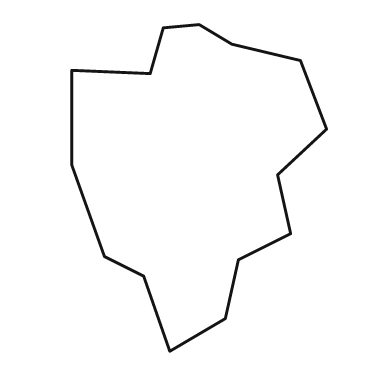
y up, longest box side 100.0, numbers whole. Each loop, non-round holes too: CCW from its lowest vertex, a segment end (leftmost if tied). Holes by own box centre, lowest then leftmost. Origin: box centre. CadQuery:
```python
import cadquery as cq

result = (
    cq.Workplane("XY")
    .moveTo(-9.0, -50.0)
    .lineTo(8.0, -40.0)
    .lineTo(12.0, -22.0)
    .lineTo(28.0, -14.0)
    .lineTo(24.0, 4.0)
    .lineTo(39.0, 18.0)
    .lineTo(31.0, 39.0)
    .lineTo(10.0, 44.0)
    .lineTo(0.0, 50.0)
    .lineTo(-11.0, 49.0)
    .lineTo(-15.0, 35.0)
    .lineTo(-39.0, 36.0)
    .lineTo(-39.0, 7.0)
    .lineTo(-29.0, -21.0)
    .lineTo(-17.0, -27.0)
    .close()
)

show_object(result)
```